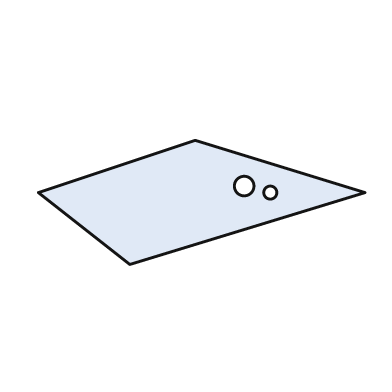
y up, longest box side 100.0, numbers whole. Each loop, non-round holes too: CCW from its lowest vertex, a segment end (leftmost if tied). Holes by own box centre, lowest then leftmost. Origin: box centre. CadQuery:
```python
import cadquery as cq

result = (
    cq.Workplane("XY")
    .moveTo(-22.0, -19.0)
    .lineTo(50.0, 3.0)
    .lineTo(-2.0, 19.0)
    .lineTo(-50.0, 3.0)
    .close()
    .moveTo(21.0, 3.0)
    .circle(2.0)
    .moveTo(13.0, 5.0)
    .circle(3.0)
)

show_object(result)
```